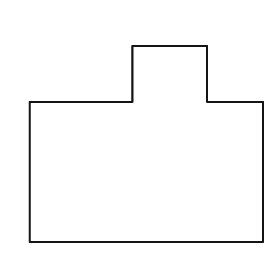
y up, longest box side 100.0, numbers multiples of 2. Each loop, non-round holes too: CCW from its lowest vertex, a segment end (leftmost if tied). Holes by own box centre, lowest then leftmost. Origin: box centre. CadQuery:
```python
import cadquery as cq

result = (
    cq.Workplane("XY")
    .moveTo(-50.0, -42.0)
    .lineTo(50.0, -42.0)
    .lineTo(50.0, 18.0)
    .lineTo(26.0, 18.0)
    .lineTo(26.0, 42.0)
    .lineTo(-6.0, 42.0)
    .lineTo(-6.0, 18.0)
    .lineTo(-50.0, 18.0)
    .close()
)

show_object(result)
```